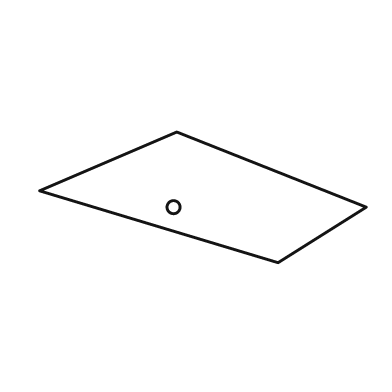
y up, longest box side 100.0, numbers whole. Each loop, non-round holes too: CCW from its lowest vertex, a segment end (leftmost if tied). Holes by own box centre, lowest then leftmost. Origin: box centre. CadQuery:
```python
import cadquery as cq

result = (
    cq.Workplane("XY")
    .moveTo(23.0, -20.0)
    .lineTo(50.0, -3.0)
    .lineTo(-8.0, 20.0)
    .lineTo(-50.0, 2.0)
    .close()
    .moveTo(-9.0, -3.0)
    .circle(2.0)
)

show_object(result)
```